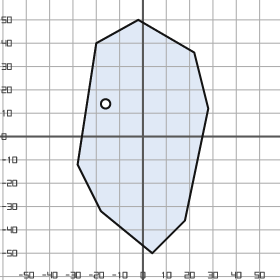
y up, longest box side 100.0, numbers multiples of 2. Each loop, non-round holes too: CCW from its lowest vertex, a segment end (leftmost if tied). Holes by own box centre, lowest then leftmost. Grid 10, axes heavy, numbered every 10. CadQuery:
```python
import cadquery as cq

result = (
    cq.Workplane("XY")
    .moveTo(4.0, -50.0)
    .lineTo(18.0, -36.0)
    .lineTo(28.0, 12.0)
    .lineTo(22.0, 36.0)
    .lineTo(-2.0, 50.0)
    .lineTo(-20.0, 40.0)
    .lineTo(-28.0, -12.0)
    .lineTo(-18.0, -32.0)
    .close()
    .moveTo(-16.0, 14.0)
    .circle(2.0)
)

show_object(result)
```